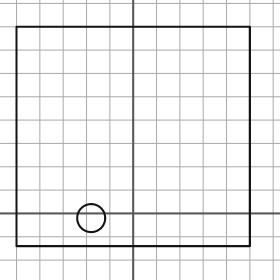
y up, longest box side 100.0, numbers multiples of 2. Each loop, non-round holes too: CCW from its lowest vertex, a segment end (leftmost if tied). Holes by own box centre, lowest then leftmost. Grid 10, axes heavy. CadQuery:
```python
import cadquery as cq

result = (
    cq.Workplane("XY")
    .moveTo(-50.0, -14.0)
    .lineTo(50.0, -14.0)
    .lineTo(50.0, 80.0)
    .lineTo(-50.0, 80.0)
    .close()
    .moveTo(-18.0, -2.0)
    .circle(6.0)
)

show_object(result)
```